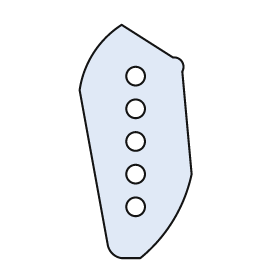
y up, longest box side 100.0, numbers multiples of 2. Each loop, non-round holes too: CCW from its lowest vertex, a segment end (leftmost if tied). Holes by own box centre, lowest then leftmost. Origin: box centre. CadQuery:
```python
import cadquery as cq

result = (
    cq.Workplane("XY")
    .moveTo(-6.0, -50.0)
    .lineTo(2.0, -50.0)
    .threePointArc((16.0, -34.0), (24.0, -14.0))
    .lineTo(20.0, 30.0)
    .threePointArc((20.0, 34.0), (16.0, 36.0))
    .lineTo(-6.0, 50.0)
    .threePointArc((-18.0, 38.0), (-24.0, 22.0))
    .lineTo(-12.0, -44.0)
    .threePointArc((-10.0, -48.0), (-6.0, -50.0))
    .close()
    .moveTo(0.0, -28.0)
    .circle(4.0)
    .moveTo(0.0, -14.0)
    .circle(4.0)
    .moveTo(0.0, 0.0)
    .circle(4.0)
    .moveTo(0.0, 14.0)
    .circle(4.0)
    .moveTo(0.0, 28.0)
    .circle(4.0)
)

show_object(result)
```